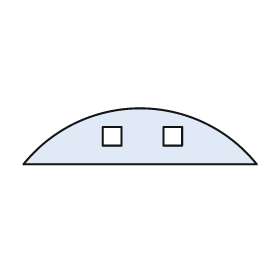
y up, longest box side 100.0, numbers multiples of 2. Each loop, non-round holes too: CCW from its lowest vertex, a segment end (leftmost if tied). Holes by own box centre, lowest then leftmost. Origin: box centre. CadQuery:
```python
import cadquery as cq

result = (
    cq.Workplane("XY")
    .moveTo(-50.0, -12.0)
    .lineTo(50.0, -12.0)
    .threePointArc((0.0, 12.0), (-50.0, -12.0))
    .close()
    .moveTo(-16.0, -4.0)
    .lineTo(-8.0, -4.0)
    .lineTo(-8.0, 4.0)
    .lineTo(-16.0, 4.0)
    .close()
    .moveTo(10.0, -4.0)
    .lineTo(18.0, -4.0)
    .lineTo(18.0, 4.0)
    .lineTo(10.0, 4.0)
    .close()
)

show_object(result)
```